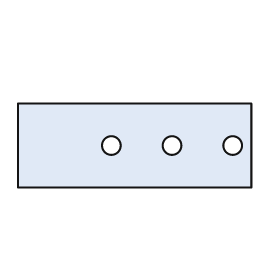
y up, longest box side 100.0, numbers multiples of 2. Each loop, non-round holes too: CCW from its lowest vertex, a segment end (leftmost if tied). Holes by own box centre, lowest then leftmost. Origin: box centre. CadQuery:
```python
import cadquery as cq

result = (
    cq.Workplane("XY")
    .moveTo(-50.0, -18.0)
    .lineTo(50.0, -18.0)
    .lineTo(50.0, 18.0)
    .lineTo(-50.0, 18.0)
    .close()
    .moveTo(-10.0, 0.0)
    .circle(4.0)
    .moveTo(16.0, 0.0)
    .circle(4.0)
    .moveTo(42.0, 0.0)
    .circle(4.0)
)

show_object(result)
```